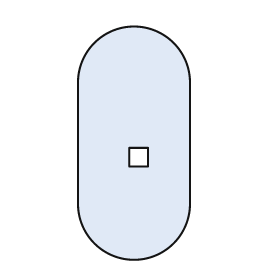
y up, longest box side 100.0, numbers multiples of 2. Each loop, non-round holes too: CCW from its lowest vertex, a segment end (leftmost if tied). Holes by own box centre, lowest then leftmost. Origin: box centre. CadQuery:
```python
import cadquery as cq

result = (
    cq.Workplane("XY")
    .moveTo(-24.0, -26.0)
    .threePointArc((0.0, -50.0), (24.0, -26.0))
    .lineTo(24.0, 26.0)
    .threePointArc((0.0, 50.0), (-24.0, 26.0))
    .close()
    .moveTo(-2.0, -10.0)
    .lineTo(6.0, -10.0)
    .lineTo(6.0, -2.0)
    .lineTo(-2.0, -2.0)
    .close()
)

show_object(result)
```